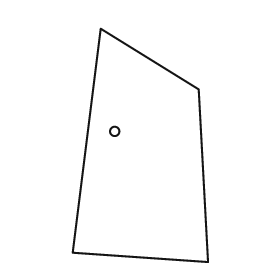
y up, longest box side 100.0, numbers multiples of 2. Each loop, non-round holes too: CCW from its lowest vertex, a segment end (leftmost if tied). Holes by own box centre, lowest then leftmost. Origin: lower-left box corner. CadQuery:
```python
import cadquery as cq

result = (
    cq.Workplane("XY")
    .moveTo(58.0, 0.0)
    .lineTo(54.0, 74.0)
    .lineTo(12.0, 100.0)
    .lineTo(0.0, 4.0)
    .close()
    .moveTo(18.0, 56.0)
    .circle(2.0)
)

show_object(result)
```